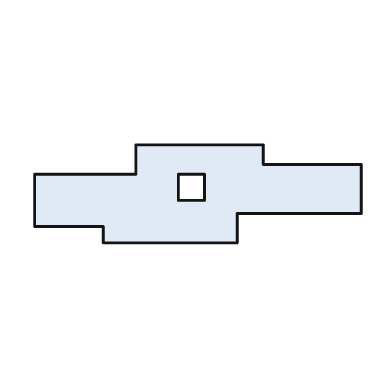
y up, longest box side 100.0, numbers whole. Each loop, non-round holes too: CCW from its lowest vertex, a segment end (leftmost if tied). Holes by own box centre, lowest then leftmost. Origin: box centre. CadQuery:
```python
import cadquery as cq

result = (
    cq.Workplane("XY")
    .moveTo(-29.0, -15.0)
    .lineTo(12.0, -15.0)
    .lineTo(12.0, -6.0)
    .lineTo(50.0, -6.0)
    .lineTo(50.0, 9.0)
    .lineTo(20.0, 9.0)
    .lineTo(20.0, 15.0)
    .lineTo(-19.0, 15.0)
    .lineTo(-19.0, 6.0)
    .lineTo(-50.0, 6.0)
    .lineTo(-50.0, -10.0)
    .lineTo(-29.0, -10.0)
    .close()
    .moveTo(-6.0, -2.0)
    .lineTo(2.0, -2.0)
    .lineTo(2.0, 6.0)
    .lineTo(-6.0, 6.0)
    .close()
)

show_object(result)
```